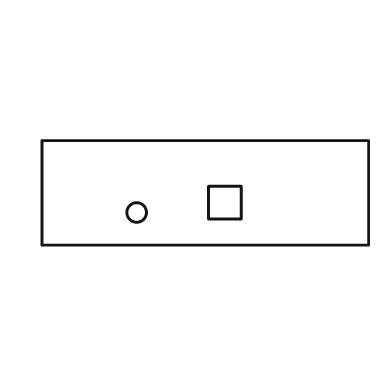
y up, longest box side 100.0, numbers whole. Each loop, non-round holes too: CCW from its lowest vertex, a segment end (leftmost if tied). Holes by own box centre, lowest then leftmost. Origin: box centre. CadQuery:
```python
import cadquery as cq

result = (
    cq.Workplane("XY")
    .moveTo(-50.0, -16.0)
    .lineTo(50.0, -16.0)
    .lineTo(50.0, 16.0)
    .lineTo(-50.0, 16.0)
    .close()
    .moveTo(-21.0, -6.0)
    .circle(3.0)
    .moveTo(1.0, -8.0)
    .lineTo(11.0, -8.0)
    .lineTo(11.0, 2.0)
    .lineTo(1.0, 2.0)
    .close()
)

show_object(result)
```